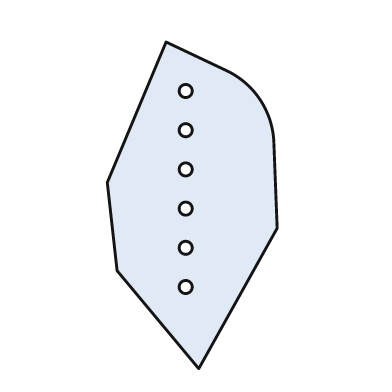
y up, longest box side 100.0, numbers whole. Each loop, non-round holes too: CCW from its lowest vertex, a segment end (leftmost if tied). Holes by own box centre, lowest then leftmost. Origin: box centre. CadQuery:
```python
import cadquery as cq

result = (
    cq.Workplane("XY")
    .moveTo(2.0, -50.0)
    .lineTo(26.0, -7.0)
    .lineTo(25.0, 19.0)
    .threePointArc((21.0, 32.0), (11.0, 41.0))
    .lineTo(-8.0, 50.0)
    .lineTo(-26.0, 7.0)
    .lineTo(-23.0, -20.0)
    .close()
    .moveTo(-2.0, -25.0)
    .circle(2.0)
    .moveTo(-2.0, -13.0)
    .circle(2.0)
    .moveTo(-2.0, -1.0)
    .circle(2.0)
    .moveTo(-2.0, 11.0)
    .circle(2.0)
    .moveTo(-2.0, 23.0)
    .circle(2.0)
    .moveTo(-2.0, 35.0)
    .circle(2.0)
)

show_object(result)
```